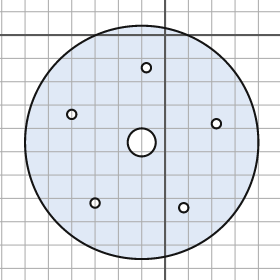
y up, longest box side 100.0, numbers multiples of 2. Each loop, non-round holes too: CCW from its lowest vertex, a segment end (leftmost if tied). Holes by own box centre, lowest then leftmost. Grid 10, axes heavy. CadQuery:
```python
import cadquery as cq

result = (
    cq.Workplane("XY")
    .moveTo(-10.0, -46.0)
    .circle(50.0)
    .moveTo(8.0, -74.0)
    .circle(2.0)
    .moveTo(-30.0, -72.0)
    .circle(2.0)
    .moveTo(-10.0, -46.0)
    .circle(6.0)
    .moveTo(22.0, -38.0)
    .circle(2.0)
    .moveTo(-40.0, -34.0)
    .circle(2.0)
    .moveTo(-8.0, -14.0)
    .circle(2.0)
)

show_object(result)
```